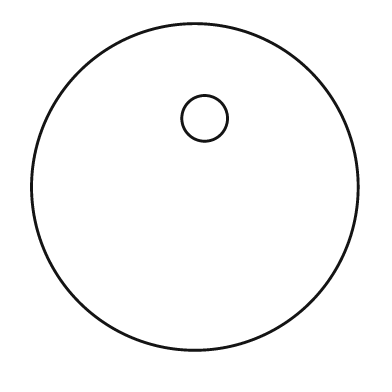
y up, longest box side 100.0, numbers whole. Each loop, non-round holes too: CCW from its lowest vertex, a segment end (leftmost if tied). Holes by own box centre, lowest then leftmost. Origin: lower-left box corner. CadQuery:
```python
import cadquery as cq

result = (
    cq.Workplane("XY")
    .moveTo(50.0, 50.0)
    .circle(50.0)
    .moveTo(53.0, 71.0)
    .circle(7.0)
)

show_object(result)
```